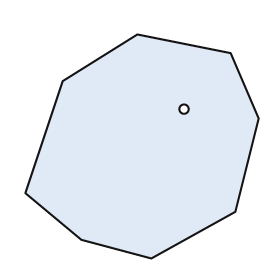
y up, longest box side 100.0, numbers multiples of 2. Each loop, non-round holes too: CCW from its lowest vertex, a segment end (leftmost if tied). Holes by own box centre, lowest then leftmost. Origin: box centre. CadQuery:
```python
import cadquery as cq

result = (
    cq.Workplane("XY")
    .moveTo(4.0, -48.0)
    .lineTo(40.0, -28.0)
    .lineTo(50.0, 12.0)
    .lineTo(38.0, 40.0)
    .lineTo(-2.0, 48.0)
    .lineTo(-34.0, 28.0)
    .lineTo(-50.0, -20.0)
    .lineTo(-26.0, -40.0)
    .close()
    .moveTo(18.0, 16.0)
    .circle(2.0)
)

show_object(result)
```